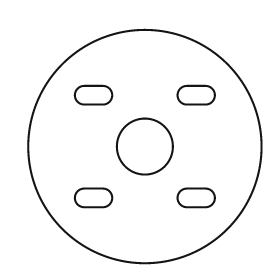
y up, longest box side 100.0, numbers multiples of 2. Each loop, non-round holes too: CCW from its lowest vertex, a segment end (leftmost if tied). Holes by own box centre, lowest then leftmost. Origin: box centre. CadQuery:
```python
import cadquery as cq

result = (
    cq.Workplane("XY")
    .moveTo(0.0, 0.0)
    .circle(50.0)
    .moveTo(-26.0, -26.0)
    .lineTo(-18.0, -26.0)
    .threePointArc((-14.0, -22.0), (-18.0, -18.0))
    .lineTo(-26.0, -18.0)
    .threePointArc((-30.0, -22.0), (-26.0, -26.0))
    .close()
    .moveTo(18.0, -26.0)
    .lineTo(26.0, -26.0)
    .threePointArc((30.0, -22.0), (26.0, -18.0))
    .lineTo(18.0, -18.0)
    .threePointArc((14.0, -22.0), (18.0, -26.0))
    .close()
    .moveTo(0.0, 0.0)
    .circle(12.0)
    .moveTo(-26.0, 18.0)
    .lineTo(-18.0, 18.0)
    .threePointArc((-14.0, 22.0), (-18.0, 26.0))
    .lineTo(-26.0, 26.0)
    .threePointArc((-30.0, 22.0), (-26.0, 18.0))
    .close()
    .moveTo(18.0, 18.0)
    .lineTo(26.0, 18.0)
    .threePointArc((30.0, 22.0), (26.0, 26.0))
    .lineTo(18.0, 26.0)
    .threePointArc((14.0, 22.0), (18.0, 18.0))
    .close()
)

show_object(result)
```